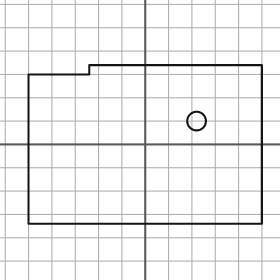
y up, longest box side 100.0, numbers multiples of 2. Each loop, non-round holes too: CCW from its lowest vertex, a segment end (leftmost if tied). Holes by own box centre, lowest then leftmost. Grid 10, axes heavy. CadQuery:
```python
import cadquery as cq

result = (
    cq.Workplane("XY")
    .moveTo(-50.0, -34.0)
    .lineTo(50.0, -34.0)
    .lineTo(50.0, 34.0)
    .lineTo(-24.0, 34.0)
    .lineTo(-24.0, 30.0)
    .lineTo(-50.0, 30.0)
    .close()
    .moveTo(22.0, 10.0)
    .circle(4.0)
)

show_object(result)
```